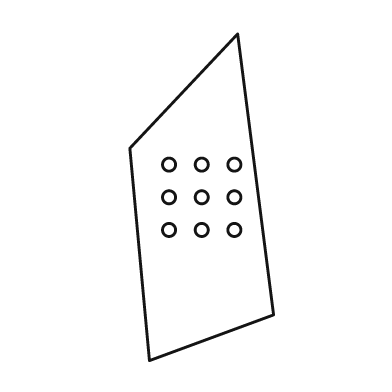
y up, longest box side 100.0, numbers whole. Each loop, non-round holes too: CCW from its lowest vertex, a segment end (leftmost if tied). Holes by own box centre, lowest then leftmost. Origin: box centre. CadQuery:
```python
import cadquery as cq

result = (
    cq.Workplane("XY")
    .moveTo(-16.0, -50.0)
    .lineTo(22.0, -36.0)
    .lineTo(11.0, 50.0)
    .lineTo(-22.0, 15.0)
    .close()
    .moveTo(-10.0, -10.0)
    .circle(2.0)
    .moveTo(0.0, -10.0)
    .circle(2.0)
    .moveTo(10.0, -10.0)
    .circle(2.0)
    .moveTo(-10.0, 0.0)
    .circle(2.0)
    .moveTo(0.0, 0.0)
    .circle(2.0)
    .moveTo(10.0, 0.0)
    .circle(2.0)
    .moveTo(-10.0, 10.0)
    .circle(2.0)
    .moveTo(0.0, 10.0)
    .circle(2.0)
    .moveTo(10.0, 10.0)
    .circle(2.0)
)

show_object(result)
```